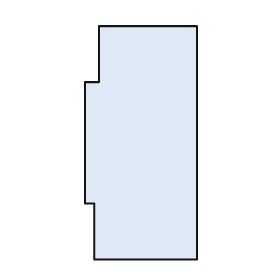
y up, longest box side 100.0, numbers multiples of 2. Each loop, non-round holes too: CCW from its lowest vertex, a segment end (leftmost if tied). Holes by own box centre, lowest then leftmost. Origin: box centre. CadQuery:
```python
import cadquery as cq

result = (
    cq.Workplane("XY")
    .moveTo(-20.0, -50.0)
    .lineTo(24.0, -50.0)
    .lineTo(24.0, 50.0)
    .lineTo(-18.0, 50.0)
    .lineTo(-18.0, 26.0)
    .lineTo(-24.0, 26.0)
    .lineTo(-24.0, -26.0)
    .lineTo(-20.0, -26.0)
    .close()
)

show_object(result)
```